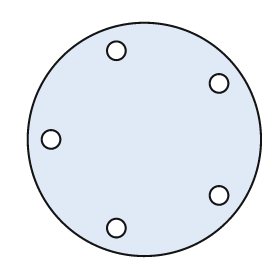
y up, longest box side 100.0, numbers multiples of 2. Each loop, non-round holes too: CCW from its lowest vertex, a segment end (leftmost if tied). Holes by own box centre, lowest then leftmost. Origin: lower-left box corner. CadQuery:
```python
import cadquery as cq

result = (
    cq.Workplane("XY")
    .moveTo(50.0, 50.0)
    .circle(50.0)
    .moveTo(38.0, 12.0)
    .circle(4.0)
    .moveTo(82.0, 26.0)
    .circle(4.0)
    .moveTo(10.0, 50.0)
    .circle(4.0)
    .moveTo(82.0, 74.0)
    .circle(4.0)
    .moveTo(38.0, 88.0)
    .circle(4.0)
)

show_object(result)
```